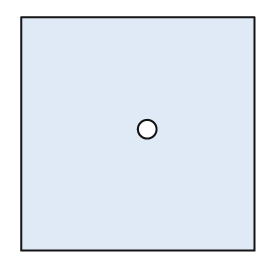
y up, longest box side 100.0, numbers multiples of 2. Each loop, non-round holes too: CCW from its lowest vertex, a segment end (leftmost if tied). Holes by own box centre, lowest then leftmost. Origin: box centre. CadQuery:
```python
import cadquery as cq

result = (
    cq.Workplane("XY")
    .moveTo(-50.0, -50.0)
    .lineTo(50.0, -50.0)
    .lineTo(50.0, 50.0)
    .lineTo(-50.0, 50.0)
    .close()
    .moveTo(4.0, 2.0)
    .circle(4.0)
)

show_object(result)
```